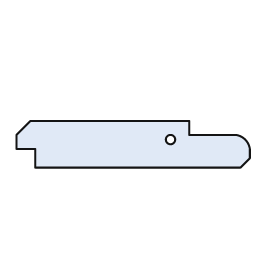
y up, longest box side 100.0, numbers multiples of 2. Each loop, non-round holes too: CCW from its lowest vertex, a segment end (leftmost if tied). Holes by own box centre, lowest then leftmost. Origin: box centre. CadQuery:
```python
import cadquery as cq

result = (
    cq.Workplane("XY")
    .moveTo(-42.0, -10.0)
    .lineTo(46.0, -10.0)
    .lineTo(50.0, -6.0)
    .lineTo(50.0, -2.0)
    .threePointArc((48.0, 2.0), (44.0, 4.0))
    .lineTo(24.0, 4.0)
    .lineTo(24.0, 10.0)
    .lineTo(-44.0, 10.0)
    .lineTo(-50.0, 4.0)
    .lineTo(-50.0, -2.0)
    .lineTo(-42.0, -2.0)
    .close()
    .moveTo(16.0, 2.0)
    .circle(2.0)
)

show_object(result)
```